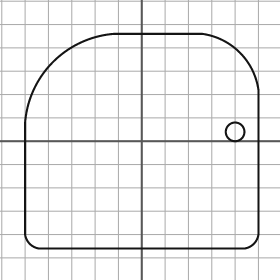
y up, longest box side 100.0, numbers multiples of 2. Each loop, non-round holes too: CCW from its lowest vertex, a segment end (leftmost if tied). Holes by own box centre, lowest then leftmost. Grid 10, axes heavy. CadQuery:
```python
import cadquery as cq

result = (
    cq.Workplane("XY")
    .moveTo(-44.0, -46.0)
    .lineTo(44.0, -46.0)
    .threePointArc((48.0, -44.0), (50.0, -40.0))
    .lineTo(50.0, 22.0)
    .threePointArc((42.0, 38.0), (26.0, 46.0))
    .lineTo(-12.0, 46.0)
    .threePointArc((-38.0, 34.0), (-50.0, 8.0))
    .lineTo(-50.0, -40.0)
    .threePointArc((-48.0, -44.0), (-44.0, -46.0))
    .close()
    .moveTo(40.0, 4.0)
    .circle(4.0)
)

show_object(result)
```